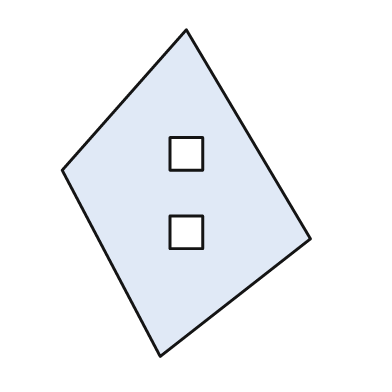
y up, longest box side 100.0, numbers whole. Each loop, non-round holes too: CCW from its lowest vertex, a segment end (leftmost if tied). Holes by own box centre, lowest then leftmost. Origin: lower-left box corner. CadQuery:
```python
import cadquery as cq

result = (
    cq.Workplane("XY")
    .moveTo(30.0, 0.0)
    .lineTo(76.0, 36.0)
    .lineTo(38.0, 100.0)
    .lineTo(0.0, 57.0)
    .close()
    .moveTo(33.0, 33.0)
    .lineTo(43.0, 33.0)
    .lineTo(43.0, 43.0)
    .lineTo(33.0, 43.0)
    .close()
    .moveTo(33.0, 57.0)
    .lineTo(43.0, 57.0)
    .lineTo(43.0, 67.0)
    .lineTo(33.0, 67.0)
    .close()
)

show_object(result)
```